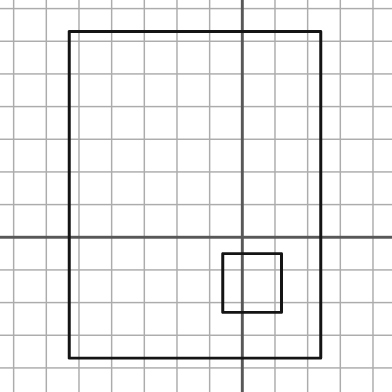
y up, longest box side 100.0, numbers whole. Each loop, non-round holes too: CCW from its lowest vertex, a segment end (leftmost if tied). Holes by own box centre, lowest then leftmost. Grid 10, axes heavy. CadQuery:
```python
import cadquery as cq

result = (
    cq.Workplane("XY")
    .moveTo(-53.0, -37.0)
    .lineTo(24.0, -37.0)
    .lineTo(24.0, 63.0)
    .lineTo(-53.0, 63.0)
    .close()
    .moveTo(-6.0, -23.0)
    .lineTo(12.0, -23.0)
    .lineTo(12.0, -5.0)
    .lineTo(-6.0, -5.0)
    .close()
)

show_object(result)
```